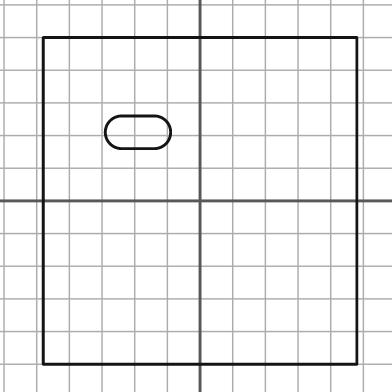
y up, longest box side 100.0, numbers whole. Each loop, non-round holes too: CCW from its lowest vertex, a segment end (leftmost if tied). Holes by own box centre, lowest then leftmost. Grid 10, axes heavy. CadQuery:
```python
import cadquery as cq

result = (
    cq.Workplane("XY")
    .moveTo(-48.0, -50.0)
    .lineTo(48.0, -50.0)
    .lineTo(48.0, 50.0)
    .lineTo(-48.0, 50.0)
    .close()
    .moveTo(-24.0, 16.0)
    .lineTo(-14.0, 16.0)
    .threePointArc((-9.0, 21.0), (-14.0, 26.0))
    .lineTo(-24.0, 26.0)
    .threePointArc((-29.0, 21.0), (-24.0, 16.0))
    .close()
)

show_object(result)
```